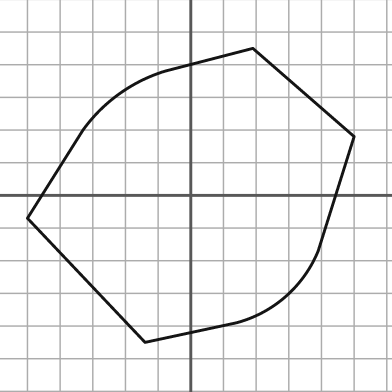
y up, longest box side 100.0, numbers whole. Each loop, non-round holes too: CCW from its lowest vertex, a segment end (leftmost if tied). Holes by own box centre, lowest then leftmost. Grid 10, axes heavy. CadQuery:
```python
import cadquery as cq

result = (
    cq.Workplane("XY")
    .moveTo(-14.0, -45.0)
    .lineTo(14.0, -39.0)
    .threePointArc((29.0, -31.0), (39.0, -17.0))
    .lineTo(50.0, 18.0)
    .lineTo(19.0, 45.0)
    .lineTo(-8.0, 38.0)
    .threePointArc((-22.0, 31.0), (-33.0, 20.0))
    .lineTo(-50.0, -7.0)
    .close()
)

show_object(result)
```